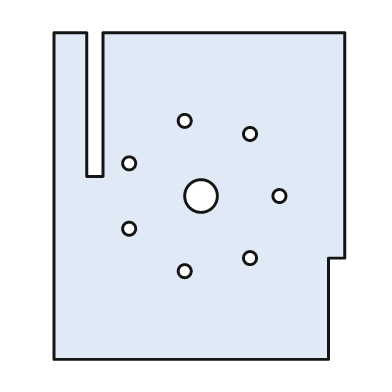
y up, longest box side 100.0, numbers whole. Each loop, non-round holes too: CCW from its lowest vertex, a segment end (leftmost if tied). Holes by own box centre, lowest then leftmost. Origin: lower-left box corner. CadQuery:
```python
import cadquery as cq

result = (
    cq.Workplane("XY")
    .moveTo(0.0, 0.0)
    .lineTo(84.0, 0.0)
    .lineTo(84.0, 31.0)
    .lineTo(89.0, 31.0)
    .lineTo(89.0, 100.0)
    .lineTo(15.0, 100.0)
    .lineTo(15.0, 56.0)
    .lineTo(10.0, 56.0)
    .lineTo(10.0, 100.0)
    .lineTo(0.0, 100.0)
    .close()
    .moveTo(40.0, 27.0)
    .circle(2.0)
    .moveTo(60.0, 31.0)
    .circle(2.0)
    .moveTo(23.0, 40.0)
    .circle(2.0)
    .moveTo(45.0, 50.0)
    .circle(5.0)
    .moveTo(69.0, 50.0)
    .circle(2.0)
    .moveTo(23.0, 60.0)
    .circle(2.0)
    .moveTo(60.0, 69.0)
    .circle(2.0)
    .moveTo(40.0, 73.0)
    .circle(2.0)
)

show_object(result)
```